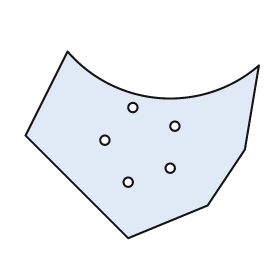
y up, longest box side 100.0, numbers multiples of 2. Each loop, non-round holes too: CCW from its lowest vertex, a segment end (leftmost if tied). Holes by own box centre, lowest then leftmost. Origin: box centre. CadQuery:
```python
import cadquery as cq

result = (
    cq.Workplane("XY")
    .moveTo(-6.0, -40.0)
    .lineTo(28.0, -26.0)
    .lineTo(44.0, -2.0)
    .lineTo(50.0, 34.0)
    .threePointArc((8.0, 20.0), (-32.0, 40.0))
    .lineTo(-50.0, 4.0)
    .close()
    .moveTo(-6.0, -16.0)
    .circle(2.0)
    .moveTo(12.0, -10.0)
    .circle(2.0)
    .moveTo(-16.0, 2.0)
    .circle(2.0)
    .moveTo(14.0, 8.0)
    .circle(2.0)
    .moveTo(-4.0, 16.0)
    .circle(2.0)
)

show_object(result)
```